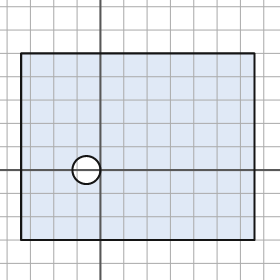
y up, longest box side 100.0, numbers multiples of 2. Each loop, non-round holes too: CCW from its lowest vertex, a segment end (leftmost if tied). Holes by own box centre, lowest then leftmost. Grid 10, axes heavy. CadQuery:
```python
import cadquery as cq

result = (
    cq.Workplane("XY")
    .moveTo(-34.0, -30.0)
    .lineTo(66.0, -30.0)
    .lineTo(66.0, 50.0)
    .lineTo(-34.0, 50.0)
    .close()
    .moveTo(-6.0, 0.0)
    .circle(6.0)
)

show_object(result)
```